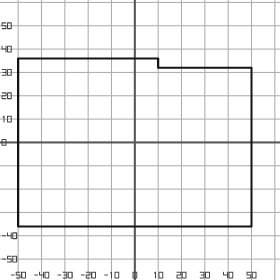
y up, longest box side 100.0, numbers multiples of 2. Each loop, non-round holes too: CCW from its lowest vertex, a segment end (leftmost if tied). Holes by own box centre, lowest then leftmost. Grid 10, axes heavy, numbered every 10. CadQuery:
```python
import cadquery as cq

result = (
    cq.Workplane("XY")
    .moveTo(-50.0, -36.0)
    .lineTo(50.0, -36.0)
    .lineTo(50.0, 32.0)
    .lineTo(10.0, 32.0)
    .lineTo(10.0, 36.0)
    .lineTo(-50.0, 36.0)
    .close()
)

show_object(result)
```